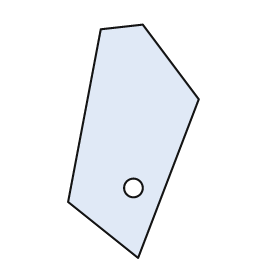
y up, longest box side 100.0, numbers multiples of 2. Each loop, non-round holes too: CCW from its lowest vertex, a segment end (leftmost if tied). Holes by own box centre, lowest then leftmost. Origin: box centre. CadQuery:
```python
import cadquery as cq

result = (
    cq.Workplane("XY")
    .moveTo(2.0, -50.0)
    .lineTo(28.0, 18.0)
    .lineTo(4.0, 50.0)
    .lineTo(-14.0, 48.0)
    .lineTo(-28.0, -26.0)
    .close()
    .moveTo(0.0, -20.0)
    .circle(4.0)
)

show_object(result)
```